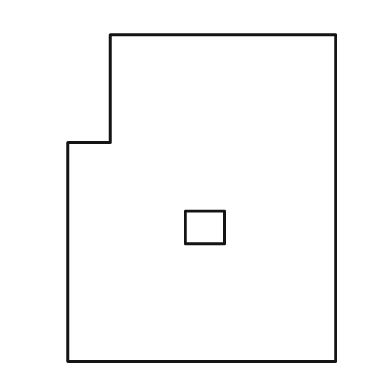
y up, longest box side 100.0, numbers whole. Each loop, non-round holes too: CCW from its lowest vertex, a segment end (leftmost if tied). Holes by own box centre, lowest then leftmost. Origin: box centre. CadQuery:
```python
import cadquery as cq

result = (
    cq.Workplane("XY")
    .moveTo(-41.0, -50.0)
    .lineTo(41.0, -50.0)
    .lineTo(41.0, 50.0)
    .lineTo(-28.0, 50.0)
    .lineTo(-28.0, 17.0)
    .lineTo(-41.0, 17.0)
    .close()
    .moveTo(-5.0, -14.0)
    .lineTo(7.0, -14.0)
    .lineTo(7.0, -4.0)
    .lineTo(-5.0, -4.0)
    .close()
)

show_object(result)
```